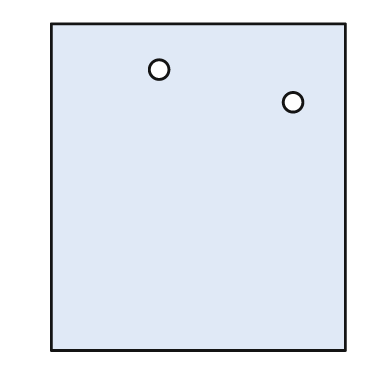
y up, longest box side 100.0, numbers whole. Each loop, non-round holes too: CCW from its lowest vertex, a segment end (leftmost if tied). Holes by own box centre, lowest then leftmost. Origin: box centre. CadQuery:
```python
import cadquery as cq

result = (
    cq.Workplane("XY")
    .moveTo(-45.0, -50.0)
    .lineTo(45.0, -50.0)
    .lineTo(45.0, 50.0)
    .lineTo(-45.0, 50.0)
    .close()
    .moveTo(29.0, 26.0)
    .circle(3.0)
    .moveTo(-12.0, 36.0)
    .circle(3.0)
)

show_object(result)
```